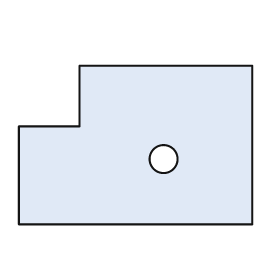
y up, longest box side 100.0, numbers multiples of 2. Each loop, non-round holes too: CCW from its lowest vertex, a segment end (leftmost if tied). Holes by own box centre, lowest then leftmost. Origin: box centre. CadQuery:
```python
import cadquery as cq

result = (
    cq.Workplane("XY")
    .moveTo(-50.0, -34.0)
    .lineTo(50.0, -34.0)
    .lineTo(50.0, 34.0)
    .lineTo(-24.0, 34.0)
    .lineTo(-24.0, 8.0)
    .lineTo(-50.0, 8.0)
    .close()
    .moveTo(12.0, -6.0)
    .circle(6.0)
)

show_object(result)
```